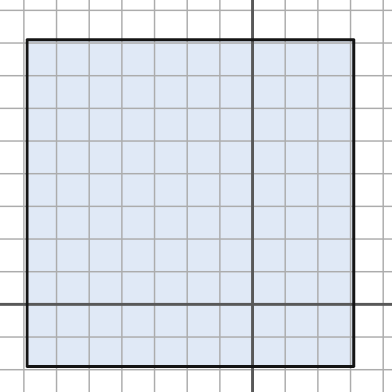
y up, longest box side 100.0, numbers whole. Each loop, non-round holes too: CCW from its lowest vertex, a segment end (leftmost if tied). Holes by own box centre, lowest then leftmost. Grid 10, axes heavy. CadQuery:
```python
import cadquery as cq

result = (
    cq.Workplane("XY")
    .moveTo(-69.0, -19.0)
    .lineTo(31.0, -19.0)
    .lineTo(31.0, 81.0)
    .lineTo(-69.0, 81.0)
    .close()
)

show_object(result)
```